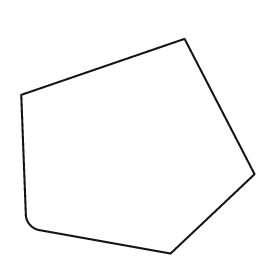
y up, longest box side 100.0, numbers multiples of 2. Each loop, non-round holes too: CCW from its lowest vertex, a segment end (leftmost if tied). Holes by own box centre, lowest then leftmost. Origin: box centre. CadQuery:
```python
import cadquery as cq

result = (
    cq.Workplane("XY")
    .moveTo(14.0, -46.0)
    .lineTo(50.0, -12.0)
    .lineTo(20.0, 46.0)
    .lineTo(-50.0, 22.0)
    .lineTo(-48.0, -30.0)
    .threePointArc((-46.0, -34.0), (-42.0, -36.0))
    .close()
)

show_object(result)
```